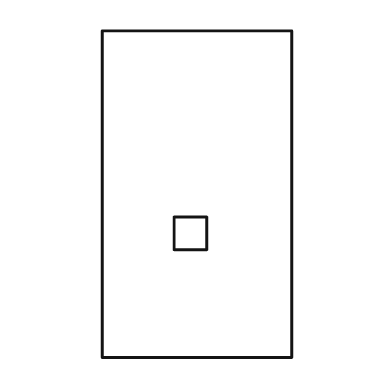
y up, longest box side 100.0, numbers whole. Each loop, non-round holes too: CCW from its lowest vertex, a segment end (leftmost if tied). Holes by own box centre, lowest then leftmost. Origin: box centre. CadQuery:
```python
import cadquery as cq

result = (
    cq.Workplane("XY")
    .moveTo(-29.0, -50.0)
    .lineTo(29.0, -50.0)
    .lineTo(29.0, 50.0)
    .lineTo(-29.0, 50.0)
    .close()
    .moveTo(-7.0, -17.0)
    .lineTo(3.0, -17.0)
    .lineTo(3.0, -7.0)
    .lineTo(-7.0, -7.0)
    .close()
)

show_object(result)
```